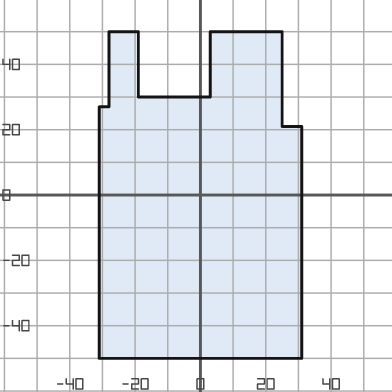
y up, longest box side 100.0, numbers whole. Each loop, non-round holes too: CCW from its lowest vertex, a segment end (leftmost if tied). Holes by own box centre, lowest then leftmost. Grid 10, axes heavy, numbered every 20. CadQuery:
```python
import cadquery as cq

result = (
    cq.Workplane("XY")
    .moveTo(-31.0, -50.0)
    .lineTo(31.0, -50.0)
    .lineTo(31.0, 21.0)
    .lineTo(25.0, 21.0)
    .lineTo(25.0, 50.0)
    .lineTo(3.0, 50.0)
    .lineTo(3.0, 30.0)
    .lineTo(-19.0, 30.0)
    .lineTo(-19.0, 50.0)
    .lineTo(-28.0, 50.0)
    .lineTo(-28.0, 27.0)
    .lineTo(-31.0, 27.0)
    .close()
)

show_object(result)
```